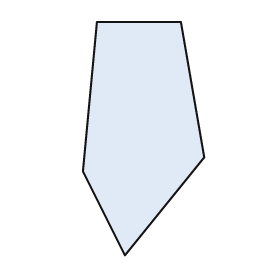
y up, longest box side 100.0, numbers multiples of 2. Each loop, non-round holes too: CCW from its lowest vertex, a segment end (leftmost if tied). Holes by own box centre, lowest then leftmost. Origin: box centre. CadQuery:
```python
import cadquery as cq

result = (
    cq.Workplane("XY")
    .moveTo(-8.0, -50.0)
    .lineTo(26.0, -8.0)
    .lineTo(16.0, 50.0)
    .lineTo(-20.0, 50.0)
    .lineTo(-26.0, -14.0)
    .close()
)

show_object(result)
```